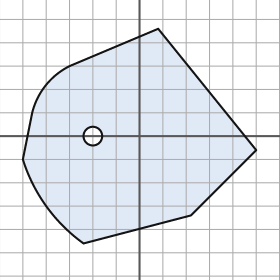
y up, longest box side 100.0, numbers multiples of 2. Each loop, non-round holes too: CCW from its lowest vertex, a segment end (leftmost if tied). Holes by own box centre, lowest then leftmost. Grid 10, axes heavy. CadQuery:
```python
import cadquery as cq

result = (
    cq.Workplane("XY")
    .moveTo(-24.0, -46.0)
    .lineTo(22.0, -34.0)
    .lineTo(50.0, -6.0)
    .lineTo(8.0, 46.0)
    .lineTo(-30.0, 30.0)
    .threePointArc((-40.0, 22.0), (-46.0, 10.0))
    .lineTo(-50.0, -10.0)
    .threePointArc((-40.0, -30.0), (-24.0, -46.0))
    .close()
    .moveTo(-20.0, 0.0)
    .circle(4.0)
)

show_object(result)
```